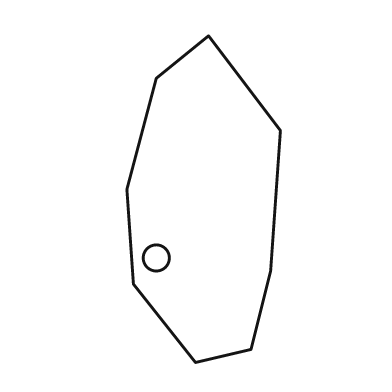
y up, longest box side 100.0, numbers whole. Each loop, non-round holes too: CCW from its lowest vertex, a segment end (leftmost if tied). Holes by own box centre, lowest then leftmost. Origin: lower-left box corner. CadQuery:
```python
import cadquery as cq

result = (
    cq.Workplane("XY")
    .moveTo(21.0, 0.0)
    .lineTo(38.0, 4.0)
    .lineTo(44.0, 28.0)
    .lineTo(47.0, 71.0)
    .lineTo(25.0, 100.0)
    .lineTo(9.0, 87.0)
    .lineTo(0.0, 53.0)
    .lineTo(2.0, 24.0)
    .close()
    .moveTo(9.0, 32.0)
    .circle(4.0)
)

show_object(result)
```